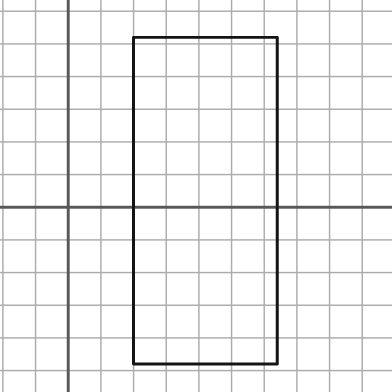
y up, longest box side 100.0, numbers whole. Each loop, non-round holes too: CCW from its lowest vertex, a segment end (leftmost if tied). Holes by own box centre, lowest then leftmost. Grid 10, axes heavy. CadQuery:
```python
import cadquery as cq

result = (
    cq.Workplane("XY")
    .moveTo(20.0, -48.0)
    .lineTo(64.0, -48.0)
    .lineTo(64.0, 52.0)
    .lineTo(20.0, 52.0)
    .close()
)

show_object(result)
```